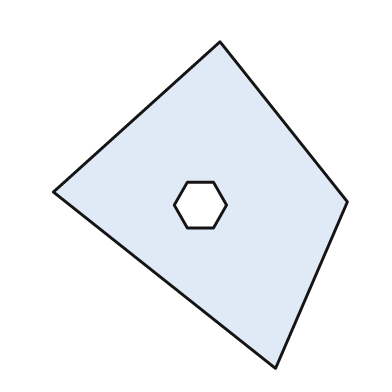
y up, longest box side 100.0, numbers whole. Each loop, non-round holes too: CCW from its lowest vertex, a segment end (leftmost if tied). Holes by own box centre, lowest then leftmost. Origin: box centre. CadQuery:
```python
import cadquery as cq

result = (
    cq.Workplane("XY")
    .moveTo(23.0, -50.0)
    .lineTo(45.0, 1.0)
    .lineTo(6.0, 50.0)
    .lineTo(-45.0, 4.0)
    .close()
    .moveTo(-4.0, -7.0)
    .lineTo(4.0, -7.0)
    .lineTo(8.0, 0.0)
    .lineTo(4.0, 7.0)
    .lineTo(-4.0, 7.0)
    .lineTo(-8.0, 0.0)
    .close()
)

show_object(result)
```